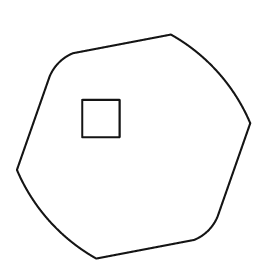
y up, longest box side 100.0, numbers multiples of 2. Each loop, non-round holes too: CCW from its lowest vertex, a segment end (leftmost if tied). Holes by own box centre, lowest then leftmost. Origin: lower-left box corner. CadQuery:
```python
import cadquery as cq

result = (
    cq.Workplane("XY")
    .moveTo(34.0, 0.0)
    .lineTo(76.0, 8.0)
    .threePointArc((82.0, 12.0), (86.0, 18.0))
    .lineTo(100.0, 58.0)
    .threePointArc((86.0, 80.0), (66.0, 96.0))
    .lineTo(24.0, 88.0)
    .threePointArc((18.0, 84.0), (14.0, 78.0))
    .lineTo(0.0, 38.0)
    .threePointArc((14.0, 16.0), (34.0, 0.0))
    .close()
    .moveTo(28.0, 52.0)
    .lineTo(44.0, 52.0)
    .lineTo(44.0, 68.0)
    .lineTo(28.0, 68.0)
    .close()
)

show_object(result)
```